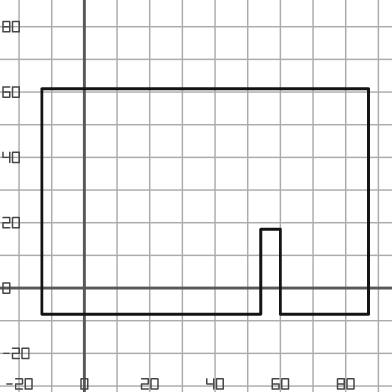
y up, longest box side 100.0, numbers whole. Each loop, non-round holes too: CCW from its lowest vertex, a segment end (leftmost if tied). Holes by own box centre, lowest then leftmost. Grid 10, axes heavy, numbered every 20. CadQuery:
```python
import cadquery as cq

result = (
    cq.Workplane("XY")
    .moveTo(-13.0, -8.0)
    .lineTo(54.0, -8.0)
    .lineTo(54.0, 18.0)
    .lineTo(60.0, 18.0)
    .lineTo(60.0, -8.0)
    .lineTo(87.0, -8.0)
    .lineTo(87.0, 61.0)
    .lineTo(-13.0, 61.0)
    .close()
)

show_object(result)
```